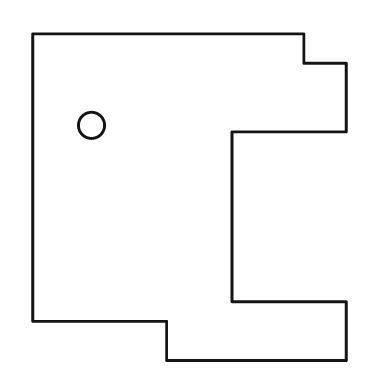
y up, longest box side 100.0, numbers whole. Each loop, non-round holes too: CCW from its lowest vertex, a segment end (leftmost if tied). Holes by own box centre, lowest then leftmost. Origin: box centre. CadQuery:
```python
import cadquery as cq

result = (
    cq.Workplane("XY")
    .moveTo(-7.0, -50.0)
    .lineTo(48.0, -50.0)
    .lineTo(48.0, -32.0)
    .lineTo(13.0, -32.0)
    .lineTo(13.0, 20.0)
    .lineTo(48.0, 20.0)
    .lineTo(48.0, 41.0)
    .lineTo(35.0, 41.0)
    .lineTo(35.0, 50.0)
    .lineTo(-48.0, 50.0)
    .lineTo(-48.0, -38.0)
    .lineTo(-7.0, -38.0)
    .close()
    .moveTo(-30.0, 22.0)
    .circle(4.0)
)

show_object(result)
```